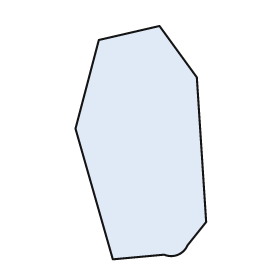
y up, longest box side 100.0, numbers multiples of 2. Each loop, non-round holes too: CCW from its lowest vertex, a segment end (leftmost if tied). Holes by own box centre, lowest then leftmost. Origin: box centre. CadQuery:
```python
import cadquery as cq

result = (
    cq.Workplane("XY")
    .moveTo(-12.0, -50.0)
    .lineTo(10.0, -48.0)
    .threePointArc((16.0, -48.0), (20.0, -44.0))
    .lineTo(28.0, -34.0)
    .lineTo(24.0, 28.0)
    .lineTo(8.0, 50.0)
    .lineTo(-18.0, 44.0)
    .lineTo(-28.0, 6.0)
    .close()
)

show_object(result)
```